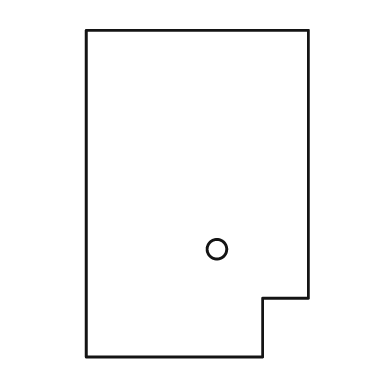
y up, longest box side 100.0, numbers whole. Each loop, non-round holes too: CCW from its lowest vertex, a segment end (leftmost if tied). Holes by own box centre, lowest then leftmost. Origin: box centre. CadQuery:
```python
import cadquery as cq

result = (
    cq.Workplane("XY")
    .moveTo(-34.0, -50.0)
    .lineTo(20.0, -50.0)
    .lineTo(20.0, -32.0)
    .lineTo(34.0, -32.0)
    .lineTo(34.0, 50.0)
    .lineTo(-34.0, 50.0)
    .close()
    .moveTo(6.0, -17.0)
    .circle(3.0)
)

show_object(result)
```